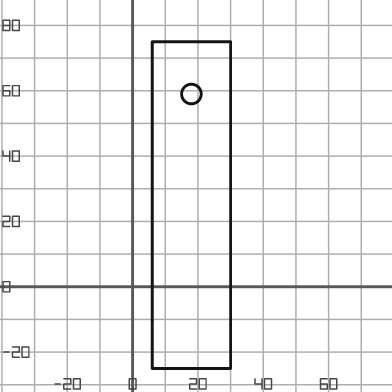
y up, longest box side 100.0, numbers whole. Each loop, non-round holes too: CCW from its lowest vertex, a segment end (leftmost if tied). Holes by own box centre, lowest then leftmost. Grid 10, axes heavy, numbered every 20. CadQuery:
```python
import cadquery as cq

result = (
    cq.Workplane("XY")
    .moveTo(6.0, -25.0)
    .lineTo(30.0, -25.0)
    .lineTo(30.0, 75.0)
    .lineTo(6.0, 75.0)
    .close()
    .moveTo(18.0, 59.0)
    .circle(3.0)
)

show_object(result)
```